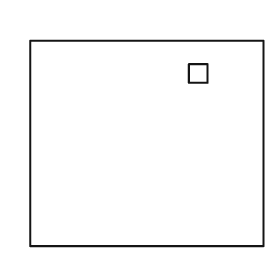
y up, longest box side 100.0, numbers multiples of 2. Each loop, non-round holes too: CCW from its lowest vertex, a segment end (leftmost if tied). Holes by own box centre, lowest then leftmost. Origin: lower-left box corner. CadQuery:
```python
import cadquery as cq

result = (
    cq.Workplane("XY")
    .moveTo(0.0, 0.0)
    .lineTo(100.0, 0.0)
    .lineTo(100.0, 88.0)
    .lineTo(0.0, 88.0)
    .close()
    .moveTo(68.0, 70.0)
    .lineTo(76.0, 70.0)
    .lineTo(76.0, 78.0)
    .lineTo(68.0, 78.0)
    .close()
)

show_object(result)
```